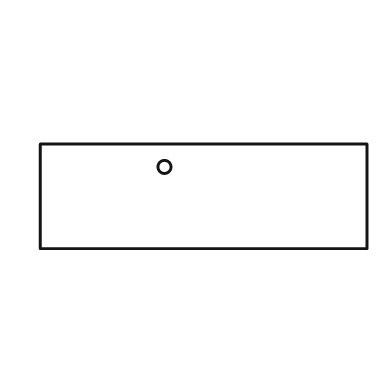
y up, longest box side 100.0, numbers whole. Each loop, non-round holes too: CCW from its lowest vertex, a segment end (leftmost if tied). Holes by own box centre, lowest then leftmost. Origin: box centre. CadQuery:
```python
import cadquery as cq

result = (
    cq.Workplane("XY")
    .moveTo(-50.0, -16.0)
    .lineTo(50.0, -16.0)
    .lineTo(50.0, 16.0)
    .lineTo(-50.0, 16.0)
    .close()
    .moveTo(-12.0, 9.0)
    .circle(2.0)
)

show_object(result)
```